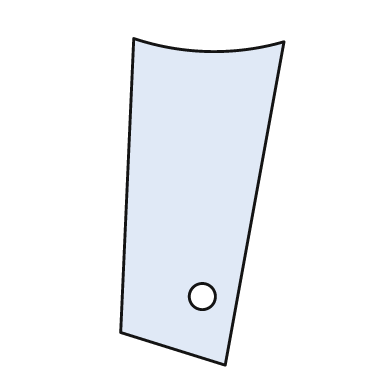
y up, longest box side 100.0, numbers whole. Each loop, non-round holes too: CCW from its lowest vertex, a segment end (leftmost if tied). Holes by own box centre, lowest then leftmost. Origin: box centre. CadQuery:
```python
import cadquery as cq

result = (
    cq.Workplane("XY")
    .moveTo(7.0, -50.0)
    .lineTo(25.0, 49.0)
    .threePointArc((2.0, 46.0), (-21.0, 50.0))
    .lineTo(-25.0, -40.0)
    .close()
    .moveTo(0.0, -29.0)
    .circle(4.0)
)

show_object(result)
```